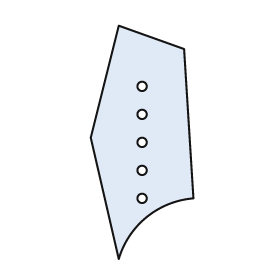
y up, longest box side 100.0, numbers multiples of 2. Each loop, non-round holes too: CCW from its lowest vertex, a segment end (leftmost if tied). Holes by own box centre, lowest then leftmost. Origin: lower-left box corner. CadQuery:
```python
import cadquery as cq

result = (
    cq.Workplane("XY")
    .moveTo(12.0, 0.0)
    .threePointArc((24.0, 18.0), (44.0, 26.0))
    .lineTo(40.0, 90.0)
    .lineTo(12.0, 100.0)
    .lineTo(0.0, 52.0)
    .close()
    .moveTo(22.0, 26.0)
    .circle(2.0)
    .moveTo(22.0, 38.0)
    .circle(2.0)
    .moveTo(22.0, 50.0)
    .circle(2.0)
    .moveTo(22.0, 62.0)
    .circle(2.0)
    .moveTo(22.0, 74.0)
    .circle(2.0)
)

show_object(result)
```